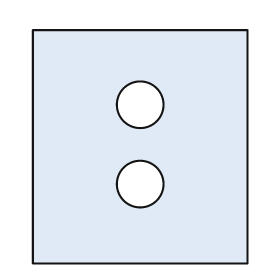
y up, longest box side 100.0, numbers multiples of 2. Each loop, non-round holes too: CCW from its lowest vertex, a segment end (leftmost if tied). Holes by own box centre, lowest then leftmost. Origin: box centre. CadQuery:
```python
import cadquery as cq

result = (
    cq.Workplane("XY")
    .moveTo(-46.0, -50.0)
    .lineTo(46.0, -50.0)
    .lineTo(46.0, 50.0)
    .lineTo(-46.0, 50.0)
    .close()
    .moveTo(0.0, -16.0)
    .circle(10.0)
    .moveTo(0.0, 18.0)
    .circle(10.0)
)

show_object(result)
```